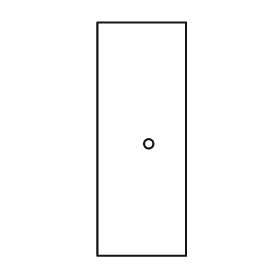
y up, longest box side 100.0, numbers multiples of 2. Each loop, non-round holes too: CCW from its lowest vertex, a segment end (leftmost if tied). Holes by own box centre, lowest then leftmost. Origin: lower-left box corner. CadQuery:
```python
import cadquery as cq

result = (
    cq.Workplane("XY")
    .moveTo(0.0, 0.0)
    .lineTo(38.0, 0.0)
    .lineTo(38.0, 100.0)
    .lineTo(0.0, 100.0)
    .close()
    .moveTo(22.0, 48.0)
    .circle(2.0)
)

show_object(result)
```